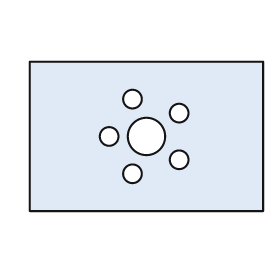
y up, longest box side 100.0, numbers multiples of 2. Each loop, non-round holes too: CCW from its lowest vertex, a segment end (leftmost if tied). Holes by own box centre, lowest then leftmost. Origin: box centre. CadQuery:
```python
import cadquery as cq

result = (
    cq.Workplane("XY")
    .moveTo(-50.0, -32.0)
    .lineTo(50.0, -32.0)
    .lineTo(50.0, 32.0)
    .lineTo(-50.0, 32.0)
    .close()
    .moveTo(-6.0, -16.0)
    .circle(4.0)
    .moveTo(14.0, -10.0)
    .circle(4.0)
    .moveTo(-16.0, 0.0)
    .circle(4.0)
    .moveTo(0.0, 0.0)
    .circle(8.0)
    .moveTo(14.0, 10.0)
    .circle(4.0)
    .moveTo(-6.0, 16.0)
    .circle(4.0)
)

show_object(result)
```